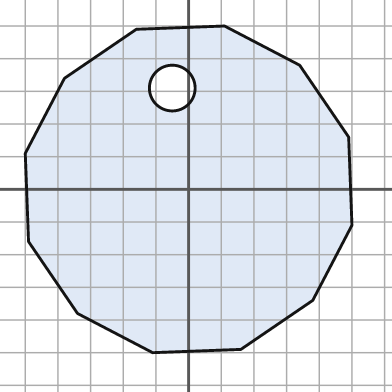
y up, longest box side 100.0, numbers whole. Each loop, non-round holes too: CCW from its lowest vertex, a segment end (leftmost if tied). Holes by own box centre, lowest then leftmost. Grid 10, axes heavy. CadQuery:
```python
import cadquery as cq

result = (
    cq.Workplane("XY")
    .moveTo(-11.0, -50.0)
    .lineTo(16.0, -49.0)
    .lineTo(38.0, -34.0)
    .lineTo(50.0, -11.0)
    .lineTo(49.0, 16.0)
    .lineTo(34.0, 38.0)
    .lineTo(11.0, 50.0)
    .lineTo(-16.0, 49.0)
    .lineTo(-38.0, 34.0)
    .lineTo(-50.0, 11.0)
    .lineTo(-49.0, -16.0)
    .lineTo(-34.0, -38.0)
    .close()
    .moveTo(-5.0, 31.0)
    .circle(7.0)
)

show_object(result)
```